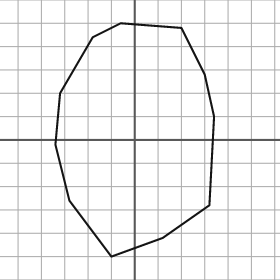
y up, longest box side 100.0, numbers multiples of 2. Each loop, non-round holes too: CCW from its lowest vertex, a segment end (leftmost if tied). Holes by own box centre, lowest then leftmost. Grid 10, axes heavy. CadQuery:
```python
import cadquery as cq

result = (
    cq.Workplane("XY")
    .moveTo(-10.0, -50.0)
    .lineTo(12.0, -42.0)
    .lineTo(32.0, -28.0)
    .lineTo(34.0, 10.0)
    .lineTo(30.0, 28.0)
    .lineTo(20.0, 48.0)
    .lineTo(-6.0, 50.0)
    .lineTo(-18.0, 44.0)
    .lineTo(-32.0, 20.0)
    .lineTo(-34.0, -2.0)
    .lineTo(-28.0, -26.0)
    .close()
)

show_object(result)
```